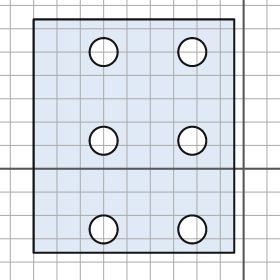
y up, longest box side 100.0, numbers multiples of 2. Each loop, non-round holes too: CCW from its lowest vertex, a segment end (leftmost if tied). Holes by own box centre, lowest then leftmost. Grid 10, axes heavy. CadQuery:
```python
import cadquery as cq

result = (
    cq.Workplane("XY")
    .moveTo(-90.0, -36.0)
    .lineTo(-4.0, -36.0)
    .lineTo(-4.0, 64.0)
    .lineTo(-90.0, 64.0)
    .close()
    .moveTo(-60.0, -26.0)
    .circle(6.0)
    .moveTo(-22.0, -26.0)
    .circle(6.0)
    .moveTo(-60.0, 12.0)
    .circle(6.0)
    .moveTo(-22.0, 12.0)
    .circle(6.0)
    .moveTo(-60.0, 50.0)
    .circle(6.0)
    .moveTo(-22.0, 50.0)
    .circle(6.0)
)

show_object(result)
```